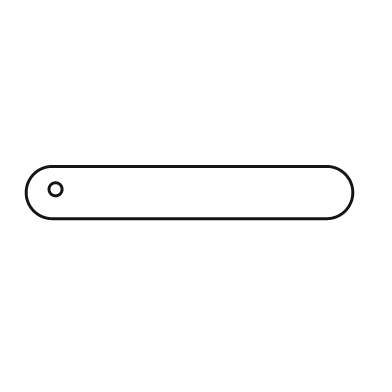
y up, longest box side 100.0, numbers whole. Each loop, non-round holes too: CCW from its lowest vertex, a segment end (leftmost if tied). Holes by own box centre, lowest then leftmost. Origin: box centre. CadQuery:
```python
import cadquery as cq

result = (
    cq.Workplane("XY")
    .moveTo(-42.0, -8.0)
    .lineTo(42.0, -8.0)
    .threePointArc((50.0, 0.0), (42.0, 8.0))
    .lineTo(-42.0, 8.0)
    .threePointArc((-50.0, 0.0), (-42.0, -8.0))
    .close()
    .moveTo(-41.0, 1.0)
    .circle(2.0)
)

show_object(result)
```